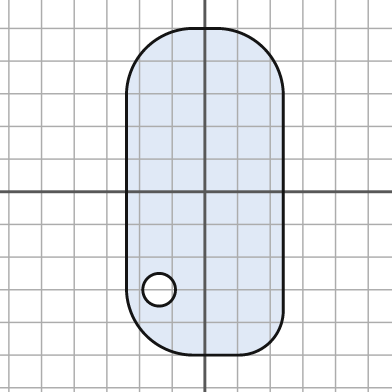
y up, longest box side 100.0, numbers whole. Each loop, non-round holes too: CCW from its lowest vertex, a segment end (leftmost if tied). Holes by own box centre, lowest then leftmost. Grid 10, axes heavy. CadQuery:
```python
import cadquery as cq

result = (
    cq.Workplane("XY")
    .moveTo(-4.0, -50.0)
    .lineTo(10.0, -50.0)
    .threePointArc((20.0, -46.0), (24.0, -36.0))
    .lineTo(24.0, 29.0)
    .threePointArc((18.0, 44.0), (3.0, 50.0))
    .lineTo(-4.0, 50.0)
    .threePointArc((-18.0, 44.0), (-24.0, 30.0))
    .lineTo(-24.0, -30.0)
    .threePointArc((-18.0, -44.0), (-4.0, -50.0))
    .close()
    .moveTo(-14.0, -30.0)
    .circle(5.0)
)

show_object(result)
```